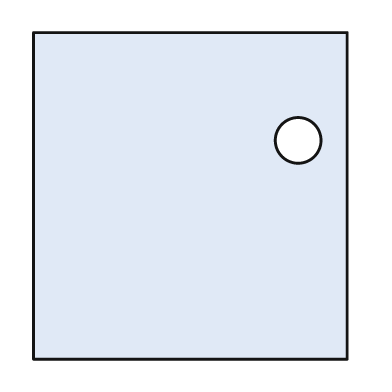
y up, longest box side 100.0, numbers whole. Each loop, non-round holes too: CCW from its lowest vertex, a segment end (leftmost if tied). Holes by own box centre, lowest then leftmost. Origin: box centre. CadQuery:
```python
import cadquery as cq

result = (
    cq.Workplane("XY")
    .moveTo(-48.0, -50.0)
    .lineTo(48.0, -50.0)
    .lineTo(48.0, 50.0)
    .lineTo(-48.0, 50.0)
    .close()
    .moveTo(33.0, 17.0)
    .circle(7.0)
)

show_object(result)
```